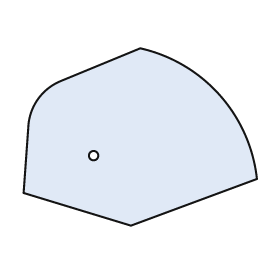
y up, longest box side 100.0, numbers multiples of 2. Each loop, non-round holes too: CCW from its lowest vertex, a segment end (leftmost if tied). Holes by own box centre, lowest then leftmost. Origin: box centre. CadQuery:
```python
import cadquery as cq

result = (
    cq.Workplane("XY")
    .moveTo(-4.0, -38.0)
    .lineTo(50.0, -18.0)
    .threePointArc((34.0, 18.0), (0.0, 38.0))
    .lineTo(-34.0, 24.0)
    .threePointArc((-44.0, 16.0), (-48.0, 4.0))
    .lineTo(-50.0, -24.0)
    .close()
    .moveTo(-20.0, -8.0)
    .circle(2.0)
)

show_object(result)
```